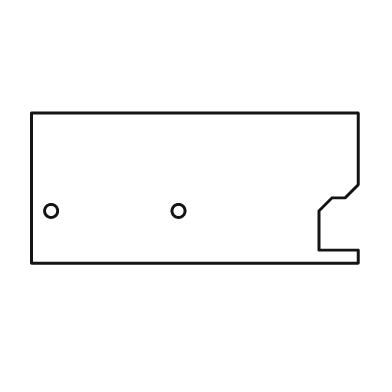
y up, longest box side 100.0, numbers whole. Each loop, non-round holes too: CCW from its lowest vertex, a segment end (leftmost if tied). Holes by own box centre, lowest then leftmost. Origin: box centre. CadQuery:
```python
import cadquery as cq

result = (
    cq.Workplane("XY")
    .moveTo(-50.0, -23.0)
    .lineTo(50.0, -23.0)
    .lineTo(50.0, -19.0)
    .lineTo(38.0, -19.0)
    .lineTo(38.0, -7.0)
    .lineTo(42.0, -3.0)
    .lineTo(46.0, -3.0)
    .lineTo(50.0, 1.0)
    .lineTo(50.0, 23.0)
    .lineTo(-50.0, 23.0)
    .close()
    .moveTo(-44.0, -7.0)
    .circle(2.0)
    .moveTo(-5.0, -7.0)
    .circle(2.0)
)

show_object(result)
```